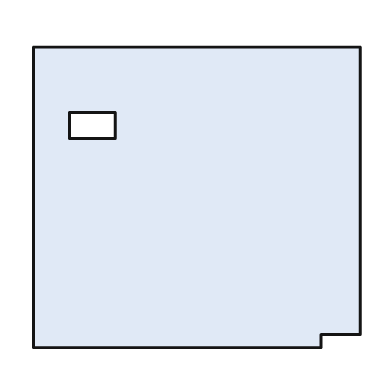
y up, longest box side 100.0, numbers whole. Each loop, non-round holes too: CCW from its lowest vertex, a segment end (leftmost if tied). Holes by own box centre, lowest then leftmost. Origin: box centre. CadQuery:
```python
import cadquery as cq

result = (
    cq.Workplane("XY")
    .moveTo(-50.0, -46.0)
    .lineTo(38.0, -46.0)
    .lineTo(38.0, -42.0)
    .lineTo(50.0, -42.0)
    .lineTo(50.0, 46.0)
    .lineTo(-50.0, 46.0)
    .close()
    .moveTo(-39.0, 18.0)
    .lineTo(-25.0, 18.0)
    .lineTo(-25.0, 26.0)
    .lineTo(-39.0, 26.0)
    .close()
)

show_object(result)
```